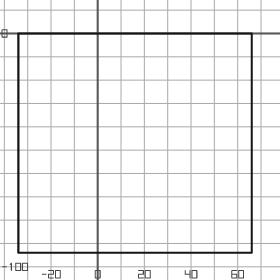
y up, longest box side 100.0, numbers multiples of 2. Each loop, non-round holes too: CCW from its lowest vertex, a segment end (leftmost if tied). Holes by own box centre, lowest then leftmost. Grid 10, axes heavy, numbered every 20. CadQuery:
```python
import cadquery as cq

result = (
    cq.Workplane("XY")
    .moveTo(-34.0, -94.0)
    .lineTo(66.0, -94.0)
    .lineTo(66.0, 0.0)
    .lineTo(-34.0, 0.0)
    .close()
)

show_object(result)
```